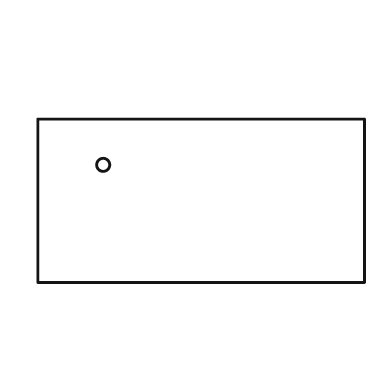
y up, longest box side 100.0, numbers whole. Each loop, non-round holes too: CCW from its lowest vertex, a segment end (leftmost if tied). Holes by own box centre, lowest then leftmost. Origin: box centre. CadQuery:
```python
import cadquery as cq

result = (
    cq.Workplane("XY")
    .moveTo(-50.0, -25.0)
    .lineTo(50.0, -25.0)
    .lineTo(50.0, 25.0)
    .lineTo(-50.0, 25.0)
    .close()
    .moveTo(-30.0, 11.0)
    .circle(2.0)
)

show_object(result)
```